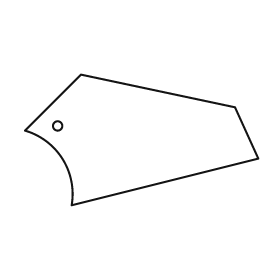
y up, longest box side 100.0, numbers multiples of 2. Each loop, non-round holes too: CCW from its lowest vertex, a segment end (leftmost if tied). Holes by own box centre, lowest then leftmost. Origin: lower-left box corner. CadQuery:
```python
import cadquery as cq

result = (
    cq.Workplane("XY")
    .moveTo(20.0, 0.0)
    .lineTo(100.0, 20.0)
    .lineTo(90.0, 42.0)
    .lineTo(24.0, 56.0)
    .lineTo(0.0, 32.0)
    .threePointArc((16.0, 20.0), (20.0, 0.0))
    .close()
    .moveTo(14.0, 34.0)
    .circle(2.0)
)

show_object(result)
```